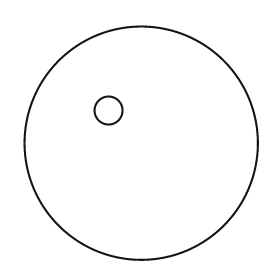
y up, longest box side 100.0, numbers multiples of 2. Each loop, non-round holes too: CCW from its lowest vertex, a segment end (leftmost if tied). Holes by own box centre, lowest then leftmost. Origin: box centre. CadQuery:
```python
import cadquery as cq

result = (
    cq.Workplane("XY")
    .moveTo(0.0, 0.0)
    .circle(50.0)
    .moveTo(-14.0, 14.0)
    .circle(6.0)
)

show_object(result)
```